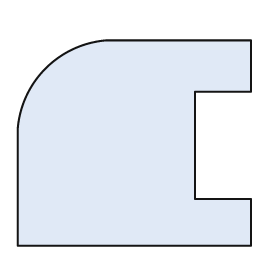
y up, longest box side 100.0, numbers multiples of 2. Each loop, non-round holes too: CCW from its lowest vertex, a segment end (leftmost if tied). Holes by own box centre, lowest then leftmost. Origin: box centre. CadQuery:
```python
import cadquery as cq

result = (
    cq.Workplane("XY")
    .moveTo(-50.0, -44.0)
    .lineTo(50.0, -44.0)
    .lineTo(50.0, -24.0)
    .lineTo(26.0, -24.0)
    .lineTo(26.0, 22.0)
    .lineTo(50.0, 22.0)
    .lineTo(50.0, 44.0)
    .lineTo(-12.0, 44.0)
    .threePointArc((-38.0, 32.0), (-50.0, 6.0))
    .close()
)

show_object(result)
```